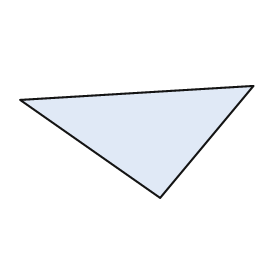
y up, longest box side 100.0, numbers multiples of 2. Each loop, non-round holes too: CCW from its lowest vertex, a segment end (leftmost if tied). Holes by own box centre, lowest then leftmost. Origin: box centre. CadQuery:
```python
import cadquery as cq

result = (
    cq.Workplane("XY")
    .moveTo(10.0, -24.0)
    .lineTo(50.0, 24.0)
    .lineTo(-50.0, 18.0)
    .close()
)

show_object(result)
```